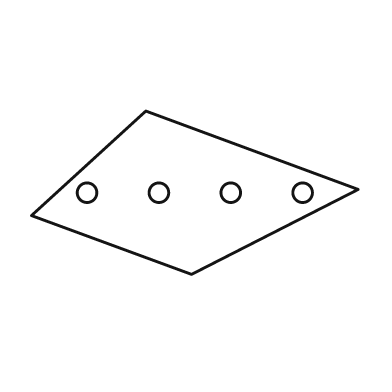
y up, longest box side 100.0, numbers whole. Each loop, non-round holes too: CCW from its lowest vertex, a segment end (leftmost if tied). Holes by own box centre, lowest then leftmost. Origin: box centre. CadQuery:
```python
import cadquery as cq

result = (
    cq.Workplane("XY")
    .moveTo(-1.0, -25.0)
    .lineTo(50.0, 1.0)
    .lineTo(-15.0, 25.0)
    .lineTo(-50.0, -7.0)
    .close()
    .moveTo(-33.0, 0.0)
    .circle(3.0)
    .moveTo(-11.0, 0.0)
    .circle(3.0)
    .moveTo(11.0, 0.0)
    .circle(3.0)
    .moveTo(33.0, 0.0)
    .circle(3.0)
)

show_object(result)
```